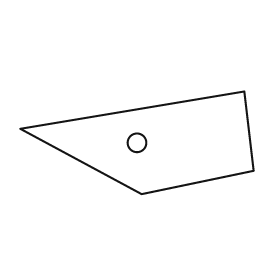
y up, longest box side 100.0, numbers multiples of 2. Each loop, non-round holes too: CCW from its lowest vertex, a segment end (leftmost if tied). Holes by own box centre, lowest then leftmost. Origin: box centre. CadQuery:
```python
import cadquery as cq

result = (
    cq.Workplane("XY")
    .moveTo(2.0, -22.0)
    .lineTo(50.0, -12.0)
    .lineTo(46.0, 22.0)
    .lineTo(-50.0, 6.0)
    .close()
    .moveTo(0.0, 0.0)
    .circle(4.0)
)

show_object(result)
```